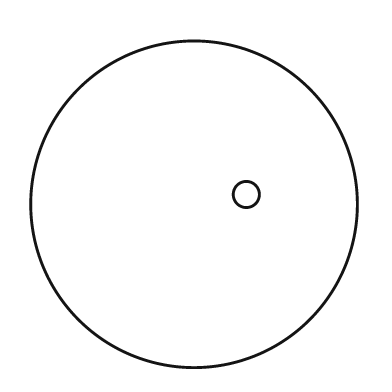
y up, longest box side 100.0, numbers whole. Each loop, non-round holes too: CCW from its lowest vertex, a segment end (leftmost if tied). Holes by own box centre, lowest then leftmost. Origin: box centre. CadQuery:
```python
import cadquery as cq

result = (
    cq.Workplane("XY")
    .moveTo(0.0, 0.0)
    .circle(50.0)
    .moveTo(16.0, 3.0)
    .circle(4.0)
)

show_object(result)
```